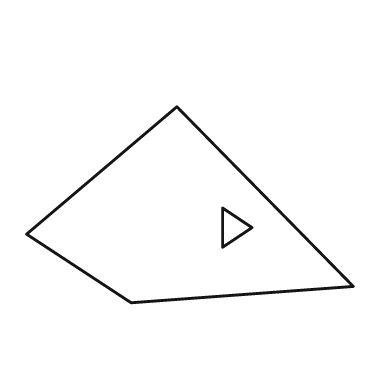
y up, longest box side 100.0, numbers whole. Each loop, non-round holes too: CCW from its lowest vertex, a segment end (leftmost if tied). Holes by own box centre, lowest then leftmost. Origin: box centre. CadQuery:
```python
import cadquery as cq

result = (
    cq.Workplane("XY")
    .moveTo(-18.0, -30.0)
    .lineTo(50.0, -25.0)
    .lineTo(-4.0, 30.0)
    .lineTo(-50.0, -9.0)
    .close()
    .moveTo(10.0, -13.0)
    .lineTo(19.0, -7.0)
    .lineTo(10.0, -1.0)
    .close()
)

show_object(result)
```